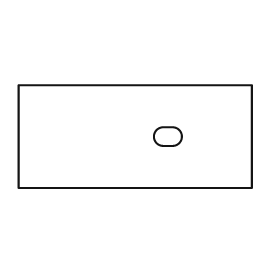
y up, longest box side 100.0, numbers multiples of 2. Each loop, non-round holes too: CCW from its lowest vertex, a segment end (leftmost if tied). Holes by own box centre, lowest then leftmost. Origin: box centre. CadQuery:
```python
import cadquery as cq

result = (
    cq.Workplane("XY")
    .moveTo(-50.0, -22.0)
    .lineTo(50.0, -22.0)
    .lineTo(50.0, 22.0)
    .lineTo(-50.0, 22.0)
    .close()
    .moveTo(12.0, -4.0)
    .lineTo(16.0, -4.0)
    .threePointArc((20.0, 0.0), (16.0, 4.0))
    .lineTo(12.0, 4.0)
    .threePointArc((8.0, 0.0), (12.0, -4.0))
    .close()
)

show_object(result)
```